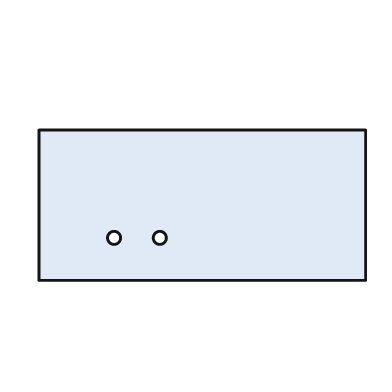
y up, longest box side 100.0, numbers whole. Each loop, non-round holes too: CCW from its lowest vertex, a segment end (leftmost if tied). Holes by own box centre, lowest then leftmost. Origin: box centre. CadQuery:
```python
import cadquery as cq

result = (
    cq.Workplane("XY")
    .moveTo(-50.0, -23.0)
    .lineTo(50.0, -23.0)
    .lineTo(50.0, 23.0)
    .lineTo(-50.0, 23.0)
    .close()
    .moveTo(-27.0, -10.0)
    .circle(2.0)
    .moveTo(-13.0, -10.0)
    .circle(2.0)
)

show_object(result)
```